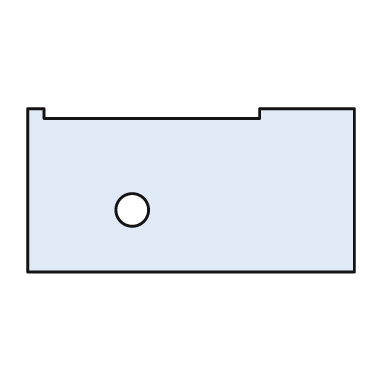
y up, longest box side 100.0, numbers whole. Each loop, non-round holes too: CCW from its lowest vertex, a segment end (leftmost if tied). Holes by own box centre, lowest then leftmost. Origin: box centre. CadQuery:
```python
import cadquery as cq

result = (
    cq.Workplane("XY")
    .moveTo(-50.0, -25.0)
    .lineTo(50.0, -25.0)
    .lineTo(50.0, 25.0)
    .lineTo(21.0, 25.0)
    .lineTo(21.0, 22.0)
    .lineTo(-45.0, 22.0)
    .lineTo(-45.0, 25.0)
    .lineTo(-50.0, 25.0)
    .close()
    .moveTo(-18.0, -6.0)
    .circle(5.0)
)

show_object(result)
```